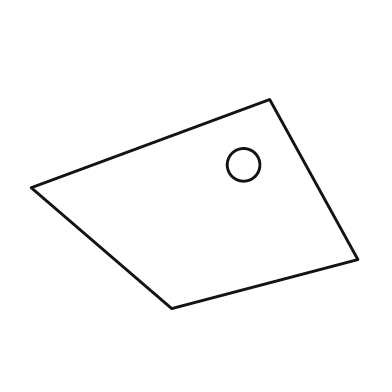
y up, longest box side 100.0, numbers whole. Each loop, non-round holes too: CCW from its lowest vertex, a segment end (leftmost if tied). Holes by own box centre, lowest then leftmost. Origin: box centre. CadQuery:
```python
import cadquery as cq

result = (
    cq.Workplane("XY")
    .moveTo(-7.0, -32.0)
    .lineTo(50.0, -17.0)
    .lineTo(23.0, 32.0)
    .lineTo(-50.0, 5.0)
    .close()
    .moveTo(15.0, 12.0)
    .circle(5.0)
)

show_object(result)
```